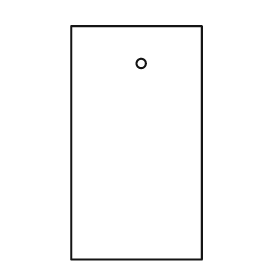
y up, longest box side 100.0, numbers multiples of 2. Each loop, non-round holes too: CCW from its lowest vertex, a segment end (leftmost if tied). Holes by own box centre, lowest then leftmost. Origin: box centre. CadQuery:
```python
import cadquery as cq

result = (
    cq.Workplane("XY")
    .moveTo(-28.0, -50.0)
    .lineTo(28.0, -50.0)
    .lineTo(28.0, 50.0)
    .lineTo(-28.0, 50.0)
    .close()
    .moveTo(2.0, 34.0)
    .circle(2.0)
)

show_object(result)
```